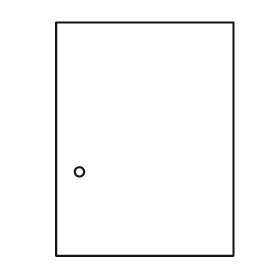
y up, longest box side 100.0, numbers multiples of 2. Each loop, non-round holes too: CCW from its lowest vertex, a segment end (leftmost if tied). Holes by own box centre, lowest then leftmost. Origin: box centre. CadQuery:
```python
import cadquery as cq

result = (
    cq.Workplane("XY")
    .moveTo(-38.0, -50.0)
    .lineTo(38.0, -50.0)
    .lineTo(38.0, 50.0)
    .lineTo(-38.0, 50.0)
    .close()
    .moveTo(-28.0, -14.0)
    .circle(2.0)
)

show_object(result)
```